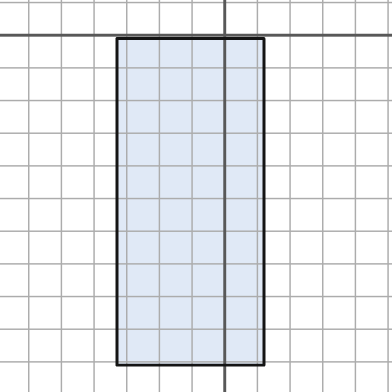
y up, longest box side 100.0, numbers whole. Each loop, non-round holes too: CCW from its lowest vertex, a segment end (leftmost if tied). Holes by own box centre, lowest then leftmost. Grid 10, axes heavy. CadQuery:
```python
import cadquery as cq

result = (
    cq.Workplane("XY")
    .moveTo(-33.0, -101.0)
    .lineTo(12.0, -101.0)
    .lineTo(12.0, -1.0)
    .lineTo(-33.0, -1.0)
    .close()
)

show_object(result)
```